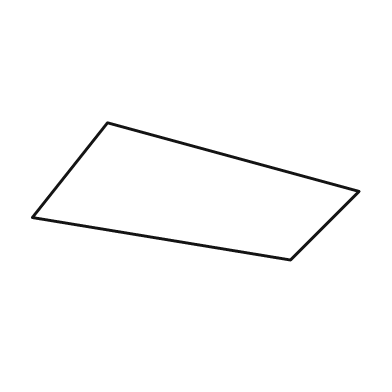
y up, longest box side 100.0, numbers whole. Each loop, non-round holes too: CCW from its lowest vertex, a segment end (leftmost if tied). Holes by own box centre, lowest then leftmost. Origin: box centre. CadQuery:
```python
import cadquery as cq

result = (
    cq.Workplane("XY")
    .moveTo(29.0, -21.0)
    .lineTo(50.0, 0.0)
    .lineTo(-27.0, 21.0)
    .lineTo(-50.0, -8.0)
    .close()
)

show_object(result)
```